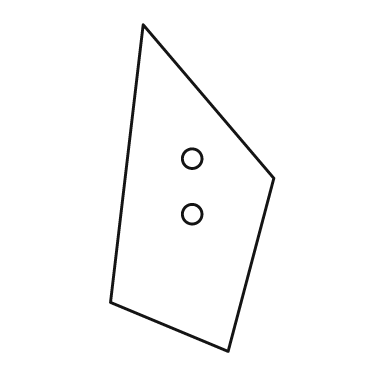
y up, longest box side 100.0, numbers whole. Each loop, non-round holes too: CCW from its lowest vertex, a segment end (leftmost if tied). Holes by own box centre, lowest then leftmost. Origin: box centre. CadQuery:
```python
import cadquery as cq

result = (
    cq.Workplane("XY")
    .moveTo(11.0, -50.0)
    .lineTo(25.0, 3.0)
    .lineTo(-15.0, 50.0)
    .lineTo(-25.0, -35.0)
    .close()
    .moveTo(0.0, -8.0)
    .circle(3.0)
    .moveTo(0.0, 9.0)
    .circle(3.0)
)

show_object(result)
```